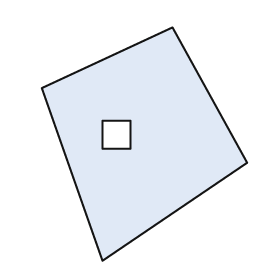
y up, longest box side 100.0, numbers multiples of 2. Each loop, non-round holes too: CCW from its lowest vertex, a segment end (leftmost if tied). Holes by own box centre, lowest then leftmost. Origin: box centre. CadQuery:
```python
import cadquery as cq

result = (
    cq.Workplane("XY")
    .moveTo(-18.0, -50.0)
    .lineTo(44.0, -8.0)
    .lineTo(12.0, 50.0)
    .lineTo(-44.0, 24.0)
    .close()
    .moveTo(-18.0, -2.0)
    .lineTo(-6.0, -2.0)
    .lineTo(-6.0, 10.0)
    .lineTo(-18.0, 10.0)
    .close()
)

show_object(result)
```